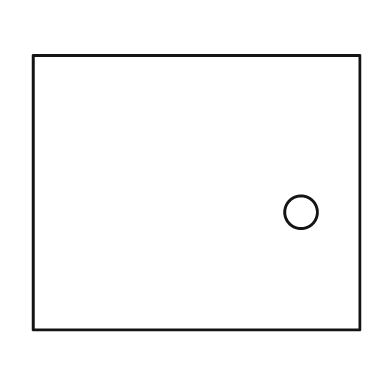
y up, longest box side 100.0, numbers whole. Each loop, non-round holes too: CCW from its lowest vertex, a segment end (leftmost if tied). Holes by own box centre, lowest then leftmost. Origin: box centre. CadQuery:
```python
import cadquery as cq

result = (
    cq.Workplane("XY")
    .moveTo(-50.0, -42.0)
    .lineTo(50.0, -42.0)
    .lineTo(50.0, 42.0)
    .lineTo(-50.0, 42.0)
    .close()
    .moveTo(32.0, -6.0)
    .circle(5.0)
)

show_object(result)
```